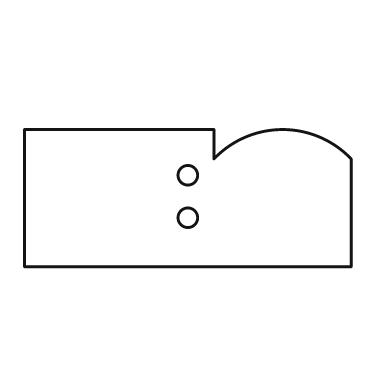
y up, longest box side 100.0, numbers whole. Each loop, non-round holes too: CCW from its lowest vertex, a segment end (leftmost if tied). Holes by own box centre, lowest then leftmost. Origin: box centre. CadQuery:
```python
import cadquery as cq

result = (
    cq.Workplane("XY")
    .moveTo(-50.0, -21.0)
    .lineTo(50.0, -21.0)
    .lineTo(50.0, 12.0)
    .threePointArc((29.0, 21.0), (8.0, 12.0))
    .lineTo(8.0, 21.0)
    .lineTo(-50.0, 21.0)
    .close()
    .moveTo(0.0, -6.0)
    .circle(3.0)
    .moveTo(0.0, 7.0)
    .circle(3.0)
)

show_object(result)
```